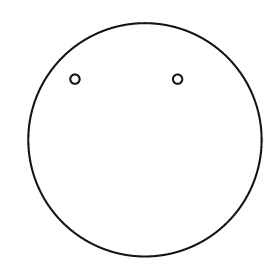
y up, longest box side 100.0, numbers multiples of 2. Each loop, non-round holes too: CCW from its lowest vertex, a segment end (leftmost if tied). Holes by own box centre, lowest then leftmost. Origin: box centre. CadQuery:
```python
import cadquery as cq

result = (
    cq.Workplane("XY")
    .moveTo(0.0, 0.0)
    .circle(50.0)
    .moveTo(-30.0, 26.0)
    .circle(2.0)
    .moveTo(14.0, 26.0)
    .circle(2.0)
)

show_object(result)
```